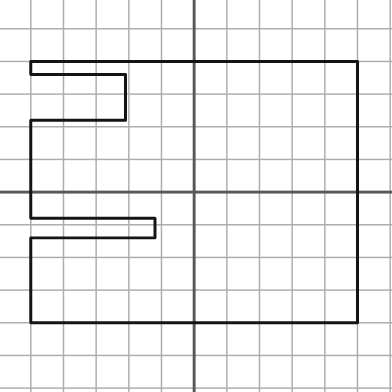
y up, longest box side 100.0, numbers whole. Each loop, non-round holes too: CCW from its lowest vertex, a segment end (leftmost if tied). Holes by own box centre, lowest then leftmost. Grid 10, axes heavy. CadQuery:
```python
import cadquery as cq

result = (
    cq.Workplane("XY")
    .moveTo(-50.0, -40.0)
    .lineTo(50.0, -40.0)
    .lineTo(50.0, 40.0)
    .lineTo(-50.0, 40.0)
    .lineTo(-50.0, 36.0)
    .lineTo(-21.0, 36.0)
    .lineTo(-21.0, 22.0)
    .lineTo(-50.0, 22.0)
    .lineTo(-50.0, -8.0)
    .lineTo(-12.0, -8.0)
    .lineTo(-12.0, -14.0)
    .lineTo(-50.0, -14.0)
    .close()
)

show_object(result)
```